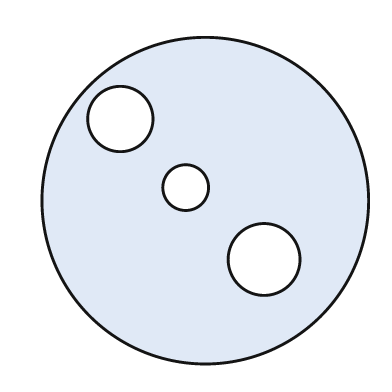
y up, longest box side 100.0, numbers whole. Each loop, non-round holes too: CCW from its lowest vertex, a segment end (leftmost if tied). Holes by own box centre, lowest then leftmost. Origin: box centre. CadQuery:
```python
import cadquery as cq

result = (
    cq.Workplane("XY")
    .moveTo(0.0, 0.0)
    .circle(50.0)
    .moveTo(18.0, -18.0)
    .circle(11.0)
    .moveTo(-6.0, 4.0)
    .circle(7.0)
    .moveTo(-26.0, 25.0)
    .circle(10.0)
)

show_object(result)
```